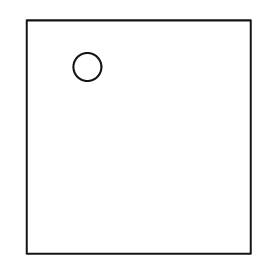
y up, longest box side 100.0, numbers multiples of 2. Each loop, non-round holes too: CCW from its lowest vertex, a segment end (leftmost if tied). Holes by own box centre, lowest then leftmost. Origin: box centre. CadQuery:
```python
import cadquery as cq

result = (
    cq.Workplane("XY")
    .moveTo(-48.0, -50.0)
    .lineTo(48.0, -50.0)
    .lineTo(48.0, 50.0)
    .lineTo(-48.0, 50.0)
    .close()
    .moveTo(-22.0, 30.0)
    .circle(6.0)
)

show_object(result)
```